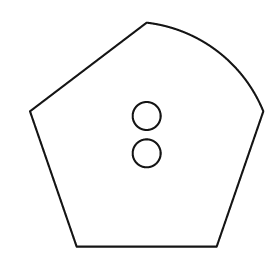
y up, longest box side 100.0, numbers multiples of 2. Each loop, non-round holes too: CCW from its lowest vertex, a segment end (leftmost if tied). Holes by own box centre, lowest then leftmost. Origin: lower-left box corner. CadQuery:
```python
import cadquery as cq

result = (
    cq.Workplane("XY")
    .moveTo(20.0, 0.0)
    .lineTo(80.0, 0.0)
    .lineTo(100.0, 58.0)
    .threePointArc((80.0, 84.0), (50.0, 96.0))
    .lineTo(0.0, 58.0)
    .close()
    .moveTo(50.0, 40.0)
    .circle(6.0)
    .moveTo(50.0, 56.0)
    .circle(6.0)
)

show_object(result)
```